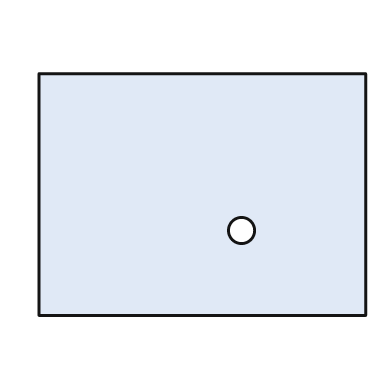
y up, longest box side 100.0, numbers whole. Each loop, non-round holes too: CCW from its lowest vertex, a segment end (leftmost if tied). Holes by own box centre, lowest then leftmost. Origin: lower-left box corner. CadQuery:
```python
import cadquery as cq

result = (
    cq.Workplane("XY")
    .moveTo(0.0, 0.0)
    .lineTo(100.0, 0.0)
    .lineTo(100.0, 74.0)
    .lineTo(0.0, 74.0)
    .close()
    .moveTo(62.0, 26.0)
    .circle(4.0)
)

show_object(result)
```